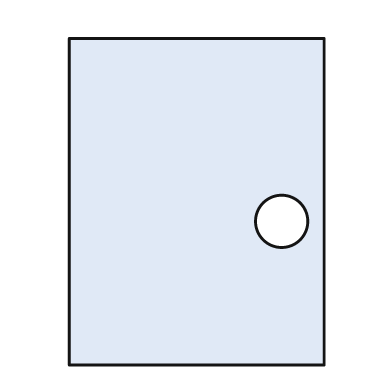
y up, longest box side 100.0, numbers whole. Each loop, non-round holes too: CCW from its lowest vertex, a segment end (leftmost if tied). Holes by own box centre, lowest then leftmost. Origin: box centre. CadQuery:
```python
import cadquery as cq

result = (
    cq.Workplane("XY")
    .moveTo(-39.0, -50.0)
    .lineTo(39.0, -50.0)
    .lineTo(39.0, 50.0)
    .lineTo(-39.0, 50.0)
    .close()
    .moveTo(26.0, -6.0)
    .circle(8.0)
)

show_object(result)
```